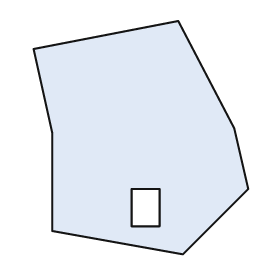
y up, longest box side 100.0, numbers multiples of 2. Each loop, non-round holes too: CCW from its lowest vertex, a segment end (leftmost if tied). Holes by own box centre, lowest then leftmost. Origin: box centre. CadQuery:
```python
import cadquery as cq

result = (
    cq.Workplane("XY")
    .moveTo(18.0, -50.0)
    .lineTo(46.0, -22.0)
    .lineTo(40.0, 4.0)
    .lineTo(16.0, 50.0)
    .lineTo(-46.0, 38.0)
    .lineTo(-38.0, 2.0)
    .lineTo(-38.0, -40.0)
    .close()
    .moveTo(-4.0, -38.0)
    .lineTo(8.0, -38.0)
    .lineTo(8.0, -22.0)
    .lineTo(-4.0, -22.0)
    .close()
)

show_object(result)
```